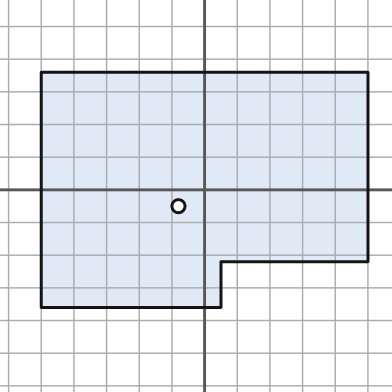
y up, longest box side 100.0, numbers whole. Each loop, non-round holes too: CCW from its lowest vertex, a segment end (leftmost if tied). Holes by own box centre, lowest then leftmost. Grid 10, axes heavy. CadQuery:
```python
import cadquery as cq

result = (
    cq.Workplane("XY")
    .moveTo(-50.0, -36.0)
    .lineTo(5.0, -36.0)
    .lineTo(5.0, -22.0)
    .lineTo(50.0, -22.0)
    .lineTo(50.0, 36.0)
    .lineTo(-50.0, 36.0)
    .close()
    .moveTo(-8.0, -5.0)
    .circle(2.0)
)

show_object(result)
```